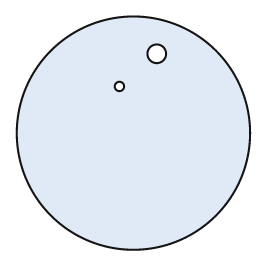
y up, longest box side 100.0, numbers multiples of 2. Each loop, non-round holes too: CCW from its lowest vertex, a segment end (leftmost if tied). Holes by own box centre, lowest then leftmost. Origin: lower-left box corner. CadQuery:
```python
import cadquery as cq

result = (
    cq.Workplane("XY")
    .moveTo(50.0, 50.0)
    .circle(50.0)
    .moveTo(44.0, 70.0)
    .circle(2.0)
    .moveTo(60.0, 84.0)
    .circle(4.0)
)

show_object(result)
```